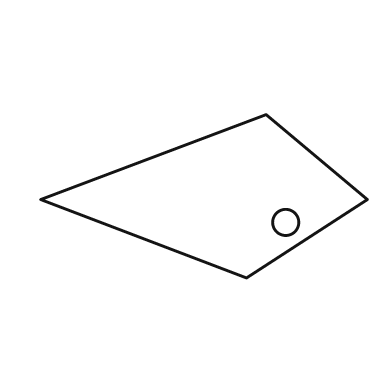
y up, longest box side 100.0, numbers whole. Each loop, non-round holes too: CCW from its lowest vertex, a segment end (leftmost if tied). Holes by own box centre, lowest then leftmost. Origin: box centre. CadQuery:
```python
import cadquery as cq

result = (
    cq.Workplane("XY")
    .moveTo(13.0, -25.0)
    .lineTo(50.0, -1.0)
    .lineTo(19.0, 25.0)
    .lineTo(-50.0, -1.0)
    .close()
    .moveTo(25.0, -8.0)
    .circle(4.0)
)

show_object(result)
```